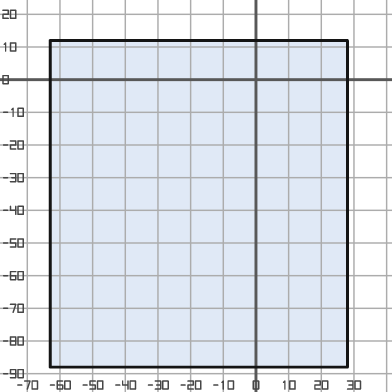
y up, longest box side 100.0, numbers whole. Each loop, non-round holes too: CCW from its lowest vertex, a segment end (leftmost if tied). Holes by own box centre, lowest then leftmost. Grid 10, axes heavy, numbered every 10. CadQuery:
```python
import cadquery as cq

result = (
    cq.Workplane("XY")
    .moveTo(-63.0, -88.0)
    .lineTo(28.0, -88.0)
    .lineTo(28.0, 12.0)
    .lineTo(-63.0, 12.0)
    .close()
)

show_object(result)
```